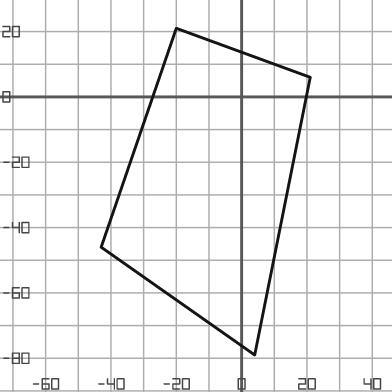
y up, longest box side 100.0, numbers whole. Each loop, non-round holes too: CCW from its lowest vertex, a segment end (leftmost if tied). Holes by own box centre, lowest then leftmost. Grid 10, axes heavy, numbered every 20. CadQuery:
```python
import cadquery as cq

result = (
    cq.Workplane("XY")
    .moveTo(4.0, -79.0)
    .lineTo(21.0, 6.0)
    .lineTo(-20.0, 21.0)
    .lineTo(-43.0, -46.0)
    .close()
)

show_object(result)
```